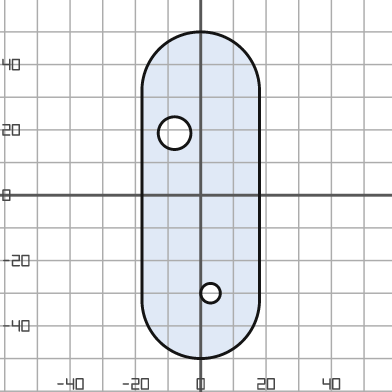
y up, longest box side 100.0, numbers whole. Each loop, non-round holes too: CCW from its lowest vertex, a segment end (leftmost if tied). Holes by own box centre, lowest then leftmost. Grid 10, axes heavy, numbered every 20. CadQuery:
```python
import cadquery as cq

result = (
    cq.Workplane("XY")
    .moveTo(-18.0, -32.0)
    .threePointArc((0.0, -50.0), (18.0, -32.0))
    .lineTo(18.0, 32.0)
    .threePointArc((0.0, 50.0), (-18.0, 32.0))
    .close()
    .moveTo(3.0, -30.0)
    .circle(3.0)
    .moveTo(-8.0, 19.0)
    .circle(5.0)
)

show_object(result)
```